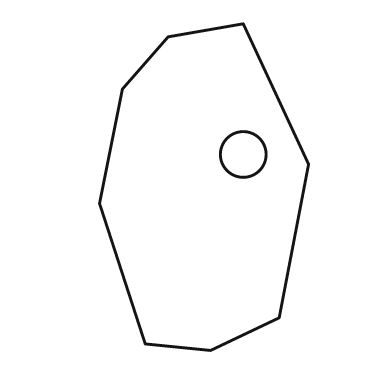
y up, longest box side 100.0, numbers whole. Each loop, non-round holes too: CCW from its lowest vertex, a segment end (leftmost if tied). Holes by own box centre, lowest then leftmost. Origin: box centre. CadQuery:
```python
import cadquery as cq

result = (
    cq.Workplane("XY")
    .moveTo(2.0, -50.0)
    .lineTo(23.0, -40.0)
    .lineTo(32.0, 7.0)
    .lineTo(12.0, 50.0)
    .lineTo(-11.0, 46.0)
    .lineTo(-25.0, 30.0)
    .lineTo(-32.0, -5.0)
    .lineTo(-18.0, -48.0)
    .close()
    .moveTo(12.0, 10.0)
    .circle(7.0)
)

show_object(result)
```